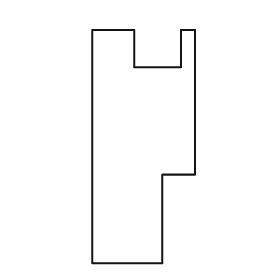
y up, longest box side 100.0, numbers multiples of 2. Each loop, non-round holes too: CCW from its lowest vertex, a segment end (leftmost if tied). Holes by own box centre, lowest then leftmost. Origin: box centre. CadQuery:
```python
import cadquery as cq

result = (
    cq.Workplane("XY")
    .moveTo(-22.0, -50.0)
    .lineTo(8.0, -50.0)
    .lineTo(8.0, -12.0)
    .lineTo(22.0, -12.0)
    .lineTo(22.0, 50.0)
    .lineTo(16.0, 50.0)
    .lineTo(16.0, 34.0)
    .lineTo(-4.0, 34.0)
    .lineTo(-4.0, 50.0)
    .lineTo(-22.0, 50.0)
    .close()
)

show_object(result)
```